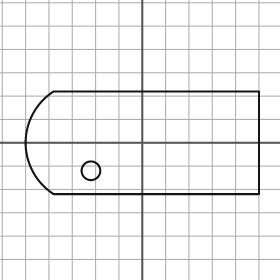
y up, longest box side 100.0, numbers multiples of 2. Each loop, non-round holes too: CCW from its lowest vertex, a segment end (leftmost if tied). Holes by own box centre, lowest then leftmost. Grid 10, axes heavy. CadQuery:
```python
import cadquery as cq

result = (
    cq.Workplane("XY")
    .moveTo(-38.0, -22.0)
    .lineTo(50.0, -22.0)
    .lineTo(50.0, 22.0)
    .lineTo(-38.0, 22.0)
    .threePointArc((-50.0, 0.0), (-38.0, -22.0))
    .close()
    .moveTo(-22.0, -12.0)
    .circle(4.0)
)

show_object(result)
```